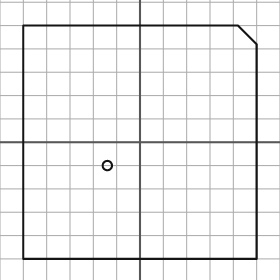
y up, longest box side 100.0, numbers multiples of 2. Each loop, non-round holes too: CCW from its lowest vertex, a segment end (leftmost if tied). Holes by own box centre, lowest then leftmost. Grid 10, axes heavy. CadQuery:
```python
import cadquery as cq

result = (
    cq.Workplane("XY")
    .moveTo(-50.0, -50.0)
    .lineTo(50.0, -50.0)
    .lineTo(50.0, 42.0)
    .lineTo(42.0, 50.0)
    .lineTo(-50.0, 50.0)
    .close()
    .moveTo(-14.0, -10.0)
    .circle(2.0)
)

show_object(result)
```